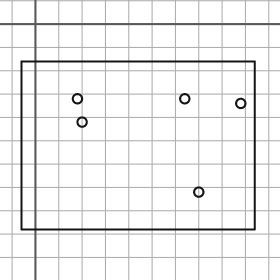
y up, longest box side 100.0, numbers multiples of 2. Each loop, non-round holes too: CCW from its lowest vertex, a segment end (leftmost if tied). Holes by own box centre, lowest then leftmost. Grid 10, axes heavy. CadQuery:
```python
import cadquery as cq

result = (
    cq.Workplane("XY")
    .moveTo(-6.0, -88.0)
    .lineTo(94.0, -88.0)
    .lineTo(94.0, -16.0)
    .lineTo(-6.0, -16.0)
    .close()
    .moveTo(70.0, -72.0)
    .circle(2.0)
    .moveTo(20.0, -42.0)
    .circle(2.0)
    .moveTo(88.0, -34.0)
    .circle(2.0)
    .moveTo(18.0, -32.0)
    .circle(2.0)
    .moveTo(64.0, -32.0)
    .circle(2.0)
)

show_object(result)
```